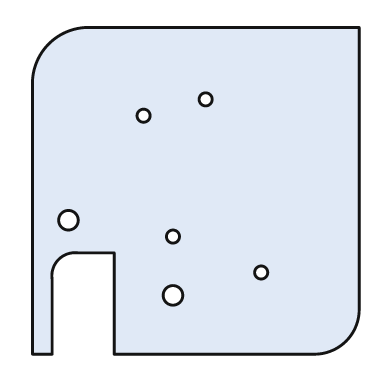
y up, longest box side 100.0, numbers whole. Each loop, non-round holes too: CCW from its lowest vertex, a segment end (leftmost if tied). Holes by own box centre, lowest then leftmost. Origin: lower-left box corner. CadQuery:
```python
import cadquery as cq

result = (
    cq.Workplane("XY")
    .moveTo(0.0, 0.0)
    .lineTo(6.0, 0.0)
    .lineTo(6.0, 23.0)
    .threePointArc((8.0, 29.0), (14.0, 31.0))
    .lineTo(25.0, 31.0)
    .lineTo(25.0, 0.0)
    .lineTo(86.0, 0.0)
    .threePointArc((96.0, 4.0), (100.0, 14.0))
    .lineTo(100.0, 100.0)
    .lineTo(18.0, 100.0)
    .threePointArc((5.0, 95.0), (0.0, 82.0))
    .close()
    .moveTo(43.0, 18.0)
    .circle(3.0)
    .moveTo(70.0, 25.0)
    .circle(2.0)
    .moveTo(43.0, 36.0)
    .circle(2.0)
    .moveTo(11.0, 41.0)
    .circle(3.0)
    .moveTo(34.0, 73.0)
    .circle(2.0)
    .moveTo(53.0, 78.0)
    .circle(2.0)
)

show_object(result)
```